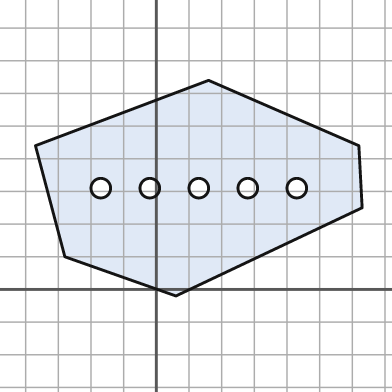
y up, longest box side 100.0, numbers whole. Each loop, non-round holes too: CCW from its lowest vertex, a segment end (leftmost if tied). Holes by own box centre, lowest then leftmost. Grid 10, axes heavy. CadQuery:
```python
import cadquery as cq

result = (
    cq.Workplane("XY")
    .moveTo(6.0, -2.0)
    .lineTo(63.0, 25.0)
    .lineTo(62.0, 44.0)
    .lineTo(16.0, 64.0)
    .lineTo(-37.0, 44.0)
    .lineTo(-28.0, 10.0)
    .close()
    .moveTo(-17.0, 31.0)
    .circle(3.0)
    .moveTo(-2.0, 31.0)
    .circle(3.0)
    .moveTo(13.0, 31.0)
    .circle(3.0)
    .moveTo(28.0, 31.0)
    .circle(3.0)
    .moveTo(43.0, 31.0)
    .circle(3.0)
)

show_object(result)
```